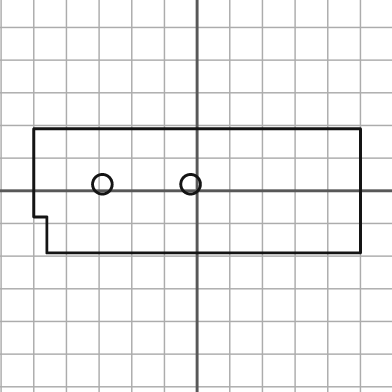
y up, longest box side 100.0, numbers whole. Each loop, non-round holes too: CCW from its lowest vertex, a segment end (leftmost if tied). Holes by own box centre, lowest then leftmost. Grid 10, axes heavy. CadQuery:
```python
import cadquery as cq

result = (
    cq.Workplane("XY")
    .moveTo(-46.0, -19.0)
    .lineTo(50.0, -19.0)
    .lineTo(50.0, 19.0)
    .lineTo(-50.0, 19.0)
    .lineTo(-50.0, -8.0)
    .lineTo(-46.0, -8.0)
    .close()
    .moveTo(-29.0, 2.0)
    .circle(3.0)
    .moveTo(-2.0, 2.0)
    .circle(3.0)
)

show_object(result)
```